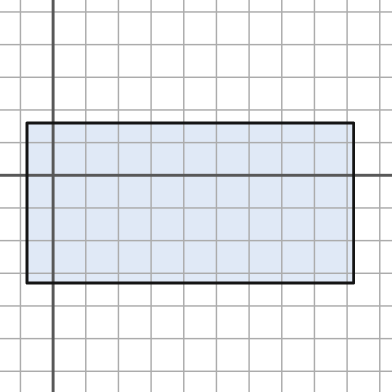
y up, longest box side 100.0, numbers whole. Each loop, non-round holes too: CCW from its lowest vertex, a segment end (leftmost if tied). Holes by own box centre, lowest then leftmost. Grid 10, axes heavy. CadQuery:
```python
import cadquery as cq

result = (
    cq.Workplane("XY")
    .moveTo(-8.0, -33.0)
    .lineTo(92.0, -33.0)
    .lineTo(92.0, 16.0)
    .lineTo(-8.0, 16.0)
    .close()
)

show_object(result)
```